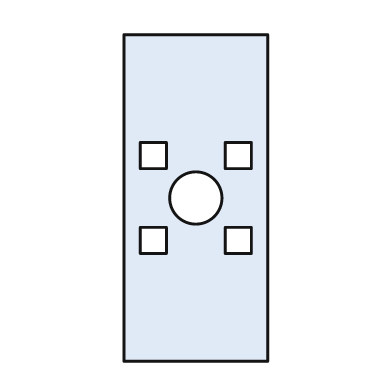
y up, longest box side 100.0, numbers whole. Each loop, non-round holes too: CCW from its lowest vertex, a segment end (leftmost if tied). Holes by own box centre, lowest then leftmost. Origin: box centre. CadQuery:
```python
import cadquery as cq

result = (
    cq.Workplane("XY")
    .moveTo(-22.0, -50.0)
    .lineTo(22.0, -50.0)
    .lineTo(22.0, 50.0)
    .lineTo(-22.0, 50.0)
    .close()
    .moveTo(-17.0, -17.0)
    .lineTo(-9.0, -17.0)
    .lineTo(-9.0, -9.0)
    .lineTo(-17.0, -9.0)
    .close()
    .moveTo(9.0, -17.0)
    .lineTo(17.0, -17.0)
    .lineTo(17.0, -9.0)
    .lineTo(9.0, -9.0)
    .close()
    .moveTo(0.0, 0.0)
    .circle(8.0)
    .moveTo(-17.0, 9.0)
    .lineTo(-9.0, 9.0)
    .lineTo(-9.0, 17.0)
    .lineTo(-17.0, 17.0)
    .close()
    .moveTo(9.0, 9.0)
    .lineTo(17.0, 9.0)
    .lineTo(17.0, 17.0)
    .lineTo(9.0, 17.0)
    .close()
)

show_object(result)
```